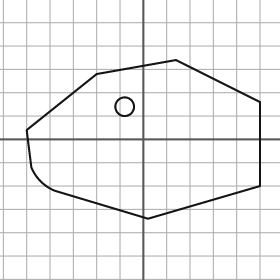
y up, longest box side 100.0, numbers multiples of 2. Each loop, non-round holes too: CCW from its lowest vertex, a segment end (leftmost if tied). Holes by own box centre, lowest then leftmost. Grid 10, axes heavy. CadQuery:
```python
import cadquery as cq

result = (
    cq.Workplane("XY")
    .moveTo(2.0, -34.0)
    .lineTo(50.0, -20.0)
    .lineTo(50.0, 16.0)
    .lineTo(14.0, 34.0)
    .lineTo(-20.0, 28.0)
    .lineTo(-50.0, 4.0)
    .lineTo(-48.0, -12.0)
    .threePointArc((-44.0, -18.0), (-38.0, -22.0))
    .close()
    .moveTo(-8.0, 14.0)
    .circle(4.0)
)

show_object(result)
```